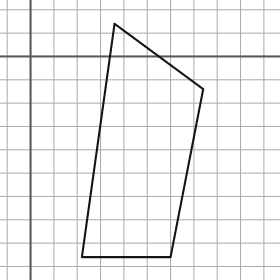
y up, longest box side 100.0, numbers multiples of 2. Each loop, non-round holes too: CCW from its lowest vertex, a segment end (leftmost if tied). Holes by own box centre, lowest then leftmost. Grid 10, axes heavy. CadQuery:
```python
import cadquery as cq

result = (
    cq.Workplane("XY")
    .moveTo(22.0, -86.0)
    .lineTo(60.0, -86.0)
    .lineTo(74.0, -14.0)
    .lineTo(36.0, 14.0)
    .close()
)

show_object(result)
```